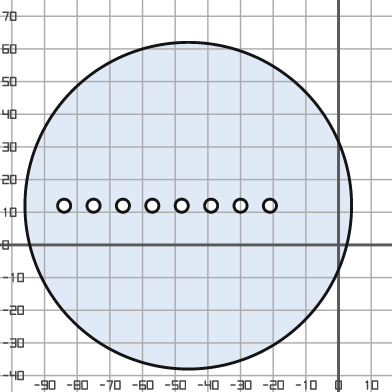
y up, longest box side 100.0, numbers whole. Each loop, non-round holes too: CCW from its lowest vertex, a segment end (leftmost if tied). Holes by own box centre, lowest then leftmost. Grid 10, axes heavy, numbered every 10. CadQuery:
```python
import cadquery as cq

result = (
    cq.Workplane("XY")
    .moveTo(-46.0, 12.0)
    .circle(50.0)
    .moveTo(-84.0, 12.0)
    .circle(2.0)
    .moveTo(-75.0, 12.0)
    .circle(2.0)
    .moveTo(-66.0, 12.0)
    .circle(2.0)
    .moveTo(-57.0, 12.0)
    .circle(2.0)
    .moveTo(-48.0, 12.0)
    .circle(2.0)
    .moveTo(-39.0, 12.0)
    .circle(2.0)
    .moveTo(-30.0, 12.0)
    .circle(2.0)
    .moveTo(-21.0, 12.0)
    .circle(2.0)
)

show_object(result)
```